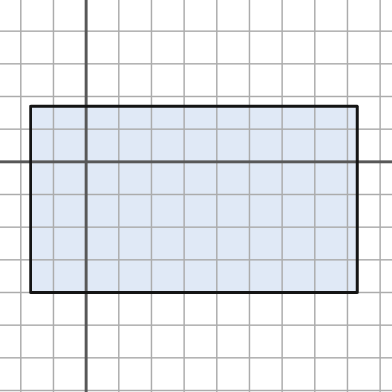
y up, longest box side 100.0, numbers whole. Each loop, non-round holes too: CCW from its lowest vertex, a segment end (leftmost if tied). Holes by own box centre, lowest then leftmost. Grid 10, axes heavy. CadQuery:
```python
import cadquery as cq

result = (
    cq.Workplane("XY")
    .moveTo(-17.0, -40.0)
    .lineTo(83.0, -40.0)
    .lineTo(83.0, 17.0)
    .lineTo(-17.0, 17.0)
    .close()
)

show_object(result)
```